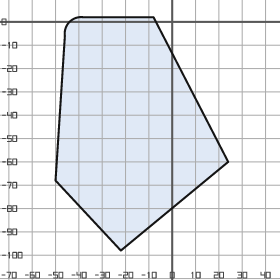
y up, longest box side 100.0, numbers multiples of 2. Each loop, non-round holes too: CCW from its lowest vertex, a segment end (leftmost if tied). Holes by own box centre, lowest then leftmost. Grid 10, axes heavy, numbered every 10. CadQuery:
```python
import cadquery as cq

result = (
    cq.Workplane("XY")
    .moveTo(-22.0, -98.0)
    .lineTo(24.0, -60.0)
    .lineTo(-8.0, 2.0)
    .lineTo(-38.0, 2.0)
    .threePointArc((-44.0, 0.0), (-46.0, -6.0))
    .lineTo(-50.0, -68.0)
    .close()
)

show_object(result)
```